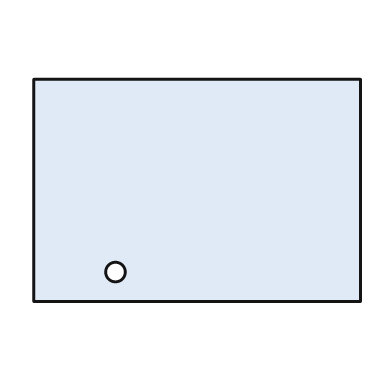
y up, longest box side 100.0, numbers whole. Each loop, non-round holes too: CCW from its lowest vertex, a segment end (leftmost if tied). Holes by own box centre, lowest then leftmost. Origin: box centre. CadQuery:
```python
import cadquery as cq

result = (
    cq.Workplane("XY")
    .moveTo(-50.0, -34.0)
    .lineTo(50.0, -34.0)
    .lineTo(50.0, 34.0)
    .lineTo(-50.0, 34.0)
    .close()
    .moveTo(-25.0, -25.0)
    .circle(3.0)
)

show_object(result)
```